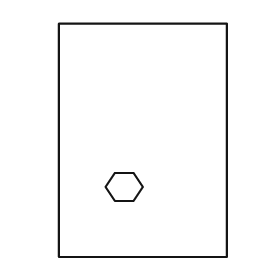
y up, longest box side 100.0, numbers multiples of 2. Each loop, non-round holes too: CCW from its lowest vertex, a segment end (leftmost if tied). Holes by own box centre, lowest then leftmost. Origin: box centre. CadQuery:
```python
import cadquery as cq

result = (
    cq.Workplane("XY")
    .moveTo(-36.0, -50.0)
    .lineTo(36.0, -50.0)
    .lineTo(36.0, 50.0)
    .lineTo(-36.0, 50.0)
    .close()
    .moveTo(-12.0, -26.0)
    .lineTo(-4.0, -26.0)
    .lineTo(0.0, -20.0)
    .lineTo(-4.0, -14.0)
    .lineTo(-12.0, -14.0)
    .lineTo(-16.0, -20.0)
    .close()
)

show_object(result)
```